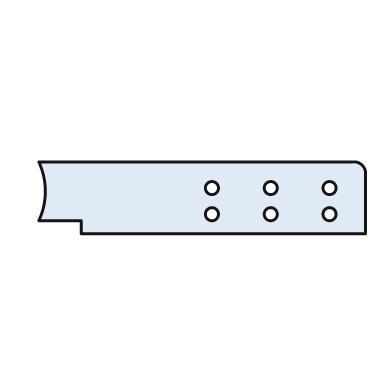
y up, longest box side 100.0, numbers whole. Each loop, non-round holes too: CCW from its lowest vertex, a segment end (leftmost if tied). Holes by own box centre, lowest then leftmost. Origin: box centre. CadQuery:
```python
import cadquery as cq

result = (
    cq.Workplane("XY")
    .moveTo(-37.0, -11.0)
    .lineTo(50.0, -11.0)
    .lineTo(50.0, 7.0)
    .threePointArc((49.0, 10.0), (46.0, 11.0))
    .lineTo(-50.0, 11.0)
    .threePointArc((-48.0, 2.0), (-50.0, -7.0))
    .lineTo(-37.0, -7.0)
    .close()
    .moveTo(3.0, -5.0)
    .circle(2.0)
    .moveTo(21.0, -5.0)
    .circle(2.0)
    .moveTo(39.0, -5.0)
    .circle(2.0)
    .moveTo(3.0, 3.0)
    .circle(2.0)
    .moveTo(21.0, 3.0)
    .circle(2.0)
    .moveTo(39.0, 3.0)
    .circle(2.0)
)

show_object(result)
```